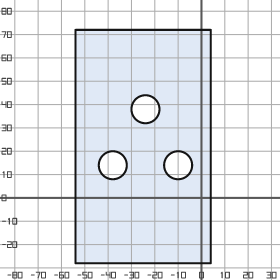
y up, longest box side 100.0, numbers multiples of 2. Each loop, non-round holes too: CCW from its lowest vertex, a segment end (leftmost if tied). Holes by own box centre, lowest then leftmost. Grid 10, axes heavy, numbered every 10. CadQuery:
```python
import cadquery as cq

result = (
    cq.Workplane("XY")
    .moveTo(-54.0, -28.0)
    .lineTo(4.0, -28.0)
    .lineTo(4.0, 72.0)
    .lineTo(-54.0, 72.0)
    .close()
    .moveTo(-38.0, 14.0)
    .circle(6.0)
    .moveTo(-10.0, 14.0)
    .circle(6.0)
    .moveTo(-24.0, 38.0)
    .circle(6.0)
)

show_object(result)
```